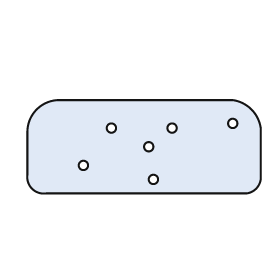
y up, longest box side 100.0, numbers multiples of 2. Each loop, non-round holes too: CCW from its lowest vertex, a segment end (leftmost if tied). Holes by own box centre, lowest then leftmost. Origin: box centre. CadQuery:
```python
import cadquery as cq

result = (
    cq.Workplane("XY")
    .moveTo(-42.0, -20.0)
    .lineTo(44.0, -20.0)
    .threePointArc((48.0, -18.0), (50.0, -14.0))
    .lineTo(50.0, 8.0)
    .threePointArc((46.0, 16.0), (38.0, 20.0))
    .lineTo(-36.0, 20.0)
    .threePointArc((-46.0, 16.0), (-50.0, 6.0))
    .lineTo(-50.0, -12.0)
    .threePointArc((-48.0, -18.0), (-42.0, -20.0))
    .close()
    .moveTo(4.0, -14.0)
    .circle(2.0)
    .moveTo(-26.0, -8.0)
    .circle(2.0)
    .moveTo(2.0, 0.0)
    .circle(2.0)
    .moveTo(-14.0, 8.0)
    .circle(2.0)
    .moveTo(12.0, 8.0)
    .circle(2.0)
    .moveTo(38.0, 10.0)
    .circle(2.0)
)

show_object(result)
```